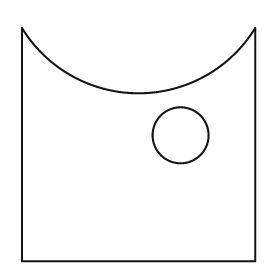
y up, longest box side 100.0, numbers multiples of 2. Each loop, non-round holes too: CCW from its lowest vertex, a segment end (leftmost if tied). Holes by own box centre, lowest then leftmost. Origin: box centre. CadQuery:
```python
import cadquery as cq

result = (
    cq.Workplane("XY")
    .moveTo(-50.0, -50.0)
    .lineTo(50.0, -50.0)
    .lineTo(50.0, 50.0)
    .threePointArc((0.0, 22.0), (-50.0, 50.0))
    .close()
    .moveTo(18.0, 4.0)
    .circle(12.0)
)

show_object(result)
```